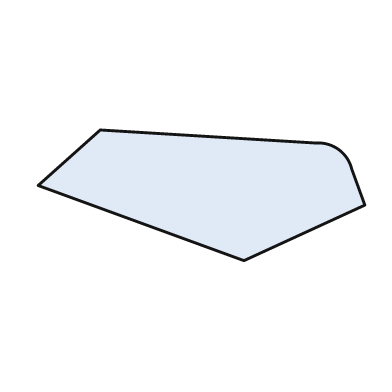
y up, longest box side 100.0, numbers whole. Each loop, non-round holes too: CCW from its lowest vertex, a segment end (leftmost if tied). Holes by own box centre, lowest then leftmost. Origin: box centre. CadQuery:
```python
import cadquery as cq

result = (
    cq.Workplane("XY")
    .moveTo(13.0, -20.0)
    .lineTo(50.0, -3.0)
    .lineTo(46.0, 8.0)
    .threePointArc((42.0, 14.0), (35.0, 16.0))
    .lineTo(-31.0, 20.0)
    .lineTo(-50.0, 3.0)
    .close()
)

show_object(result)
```